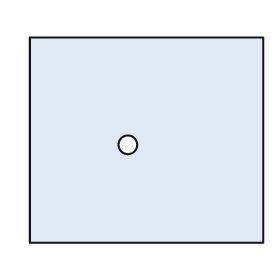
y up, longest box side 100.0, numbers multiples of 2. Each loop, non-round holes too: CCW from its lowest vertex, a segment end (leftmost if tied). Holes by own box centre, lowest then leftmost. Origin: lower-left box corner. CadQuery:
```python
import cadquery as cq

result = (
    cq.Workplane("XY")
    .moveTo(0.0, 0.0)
    .lineTo(100.0, 0.0)
    .lineTo(100.0, 88.0)
    .lineTo(0.0, 88.0)
    .close()
    .moveTo(42.0, 42.0)
    .circle(4.0)
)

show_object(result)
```